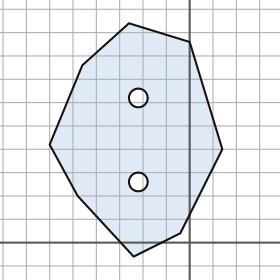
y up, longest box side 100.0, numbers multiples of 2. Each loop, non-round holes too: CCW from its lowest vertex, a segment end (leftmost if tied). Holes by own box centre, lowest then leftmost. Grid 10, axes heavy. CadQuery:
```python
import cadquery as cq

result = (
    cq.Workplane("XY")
    .moveTo(-24.0, -6.0)
    .lineTo(-4.0, 4.0)
    .lineTo(14.0, 40.0)
    .lineTo(0.0, 86.0)
    .lineTo(-26.0, 94.0)
    .lineTo(-46.0, 76.0)
    .lineTo(-60.0, 42.0)
    .lineTo(-48.0, 20.0)
    .close()
    .moveTo(-22.0, 26.0)
    .circle(4.0)
    .moveTo(-22.0, 62.0)
    .circle(4.0)
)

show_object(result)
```